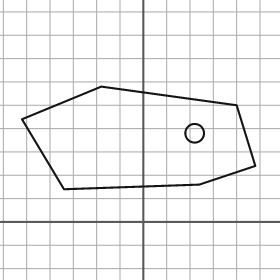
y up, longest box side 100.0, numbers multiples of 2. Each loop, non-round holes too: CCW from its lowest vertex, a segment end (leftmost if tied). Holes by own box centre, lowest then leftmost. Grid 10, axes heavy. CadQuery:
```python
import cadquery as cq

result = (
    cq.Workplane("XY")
    .moveTo(-34.0, 14.0)
    .lineTo(24.0, 16.0)
    .lineTo(48.0, 24.0)
    .lineTo(40.0, 50.0)
    .lineTo(-18.0, 58.0)
    .lineTo(-52.0, 44.0)
    .close()
    .moveTo(22.0, 38.0)
    .circle(4.0)
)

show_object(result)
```